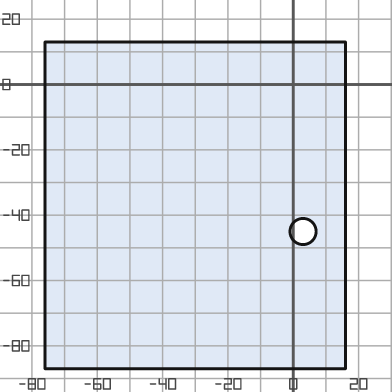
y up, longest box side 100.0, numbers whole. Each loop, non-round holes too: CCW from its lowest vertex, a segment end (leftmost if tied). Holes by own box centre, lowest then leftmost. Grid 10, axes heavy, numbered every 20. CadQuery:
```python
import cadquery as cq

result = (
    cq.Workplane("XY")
    .moveTo(-76.0, -87.0)
    .lineTo(16.0, -87.0)
    .lineTo(16.0, 13.0)
    .lineTo(-76.0, 13.0)
    .close()
    .moveTo(3.0, -45.0)
    .circle(4.0)
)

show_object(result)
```